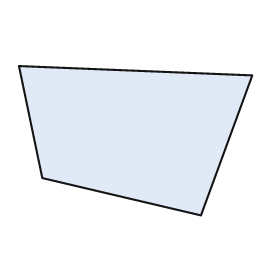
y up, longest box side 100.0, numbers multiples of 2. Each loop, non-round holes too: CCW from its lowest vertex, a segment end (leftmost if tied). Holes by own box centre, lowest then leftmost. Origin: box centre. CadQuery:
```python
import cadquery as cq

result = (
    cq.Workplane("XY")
    .moveTo(28.0, -32.0)
    .lineTo(50.0, 28.0)
    .lineTo(-50.0, 32.0)
    .lineTo(-40.0, -16.0)
    .close()
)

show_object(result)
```